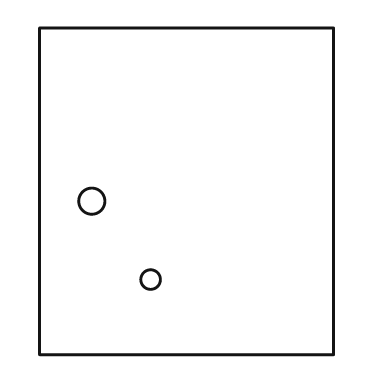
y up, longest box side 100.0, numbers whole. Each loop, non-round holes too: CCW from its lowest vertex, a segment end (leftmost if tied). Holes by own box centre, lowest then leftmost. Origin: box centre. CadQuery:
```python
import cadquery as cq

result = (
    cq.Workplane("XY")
    .moveTo(-45.0, -50.0)
    .lineTo(45.0, -50.0)
    .lineTo(45.0, 50.0)
    .lineTo(-45.0, 50.0)
    .close()
    .moveTo(-11.0, -27.0)
    .circle(3.0)
    .moveTo(-29.0, -3.0)
    .circle(4.0)
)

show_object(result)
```